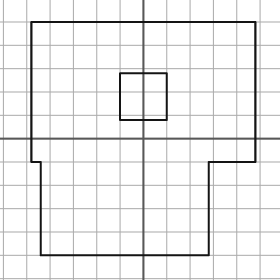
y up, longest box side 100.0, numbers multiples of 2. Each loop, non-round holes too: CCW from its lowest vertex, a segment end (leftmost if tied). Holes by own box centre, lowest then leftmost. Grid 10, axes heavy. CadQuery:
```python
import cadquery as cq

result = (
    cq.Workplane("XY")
    .moveTo(-44.0, -50.0)
    .lineTo(28.0, -50.0)
    .lineTo(28.0, -10.0)
    .lineTo(48.0, -10.0)
    .lineTo(48.0, 50.0)
    .lineTo(-48.0, 50.0)
    .lineTo(-48.0, -10.0)
    .lineTo(-44.0, -10.0)
    .close()
    .moveTo(-10.0, 8.0)
    .lineTo(10.0, 8.0)
    .lineTo(10.0, 28.0)
    .lineTo(-10.0, 28.0)
    .close()
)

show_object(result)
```